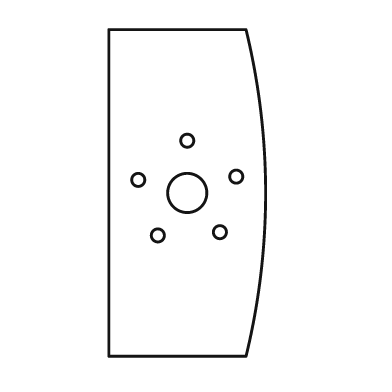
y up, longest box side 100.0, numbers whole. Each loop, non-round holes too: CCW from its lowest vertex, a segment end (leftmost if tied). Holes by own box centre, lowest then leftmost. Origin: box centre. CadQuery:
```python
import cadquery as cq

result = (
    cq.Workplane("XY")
    .moveTo(-24.0, -50.0)
    .lineTo(18.0, -50.0)
    .threePointArc((24.0, 0.0), (18.0, 50.0))
    .lineTo(-24.0, 50.0)
    .close()
    .moveTo(-9.0, -13.0)
    .circle(2.0)
    .moveTo(10.0, -12.0)
    .circle(2.0)
    .moveTo(0.0, 0.0)
    .circle(6.0)
    .moveTo(-15.0, 4.0)
    .circle(2.0)
    .moveTo(15.0, 5.0)
    .circle(2.0)
    .moveTo(0.0, 16.0)
    .circle(2.0)
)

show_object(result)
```